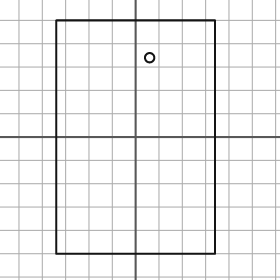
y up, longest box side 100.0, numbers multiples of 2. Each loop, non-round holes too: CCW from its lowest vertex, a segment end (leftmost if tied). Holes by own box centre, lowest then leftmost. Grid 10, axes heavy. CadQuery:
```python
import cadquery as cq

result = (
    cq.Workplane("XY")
    .moveTo(-34.0, -50.0)
    .lineTo(34.0, -50.0)
    .lineTo(34.0, 50.0)
    .lineTo(-34.0, 50.0)
    .close()
    .moveTo(6.0, 34.0)
    .circle(2.0)
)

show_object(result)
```